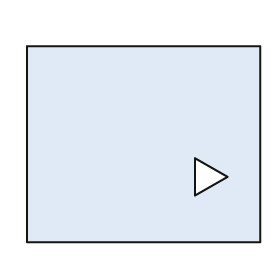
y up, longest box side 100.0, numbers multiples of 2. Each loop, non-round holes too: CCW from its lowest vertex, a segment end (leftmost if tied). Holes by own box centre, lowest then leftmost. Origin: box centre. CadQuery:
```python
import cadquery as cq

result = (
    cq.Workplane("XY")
    .moveTo(-50.0, -42.0)
    .lineTo(50.0, -42.0)
    .lineTo(50.0, 42.0)
    .lineTo(-50.0, 42.0)
    .close()
    .moveTo(22.0, -22.0)
    .lineTo(36.0, -14.0)
    .lineTo(22.0, -6.0)
    .close()
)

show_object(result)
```